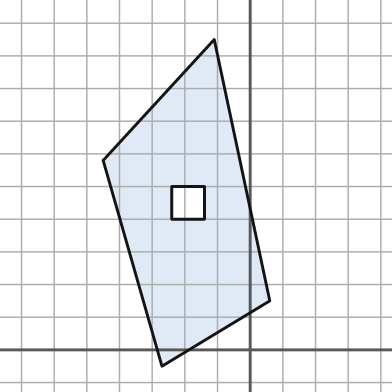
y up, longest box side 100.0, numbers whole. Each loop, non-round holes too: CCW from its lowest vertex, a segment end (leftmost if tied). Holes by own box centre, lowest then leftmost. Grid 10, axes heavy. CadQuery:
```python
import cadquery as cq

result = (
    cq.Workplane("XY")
    .moveTo(-27.0, -5.0)
    .lineTo(6.0, 15.0)
    .lineTo(-11.0, 95.0)
    .lineTo(-45.0, 58.0)
    .close()
    .moveTo(-24.0, 40.0)
    .lineTo(-14.0, 40.0)
    .lineTo(-14.0, 50.0)
    .lineTo(-24.0, 50.0)
    .close()
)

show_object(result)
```